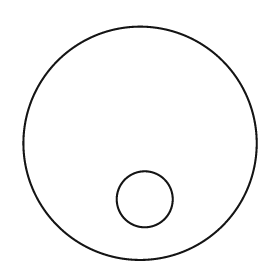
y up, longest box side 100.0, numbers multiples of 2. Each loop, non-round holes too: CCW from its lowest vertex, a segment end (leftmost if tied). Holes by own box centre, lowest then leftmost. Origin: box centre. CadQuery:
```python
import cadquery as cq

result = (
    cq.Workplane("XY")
    .moveTo(0.0, 0.0)
    .circle(50.0)
    .moveTo(2.0, -24.0)
    .circle(12.0)
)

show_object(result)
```